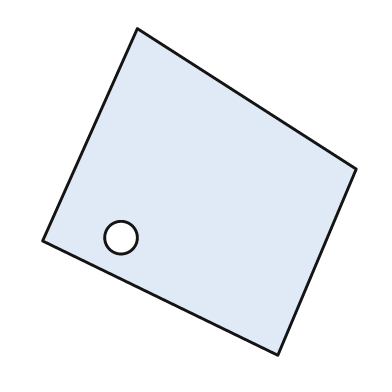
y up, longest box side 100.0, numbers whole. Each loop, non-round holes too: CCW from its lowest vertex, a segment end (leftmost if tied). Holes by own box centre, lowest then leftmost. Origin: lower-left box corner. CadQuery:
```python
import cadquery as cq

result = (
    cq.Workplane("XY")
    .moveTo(72.0, 0.0)
    .lineTo(96.0, 57.0)
    .lineTo(29.0, 100.0)
    .lineTo(0.0, 35.0)
    .close()
    .moveTo(24.0, 36.0)
    .circle(5.0)
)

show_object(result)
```